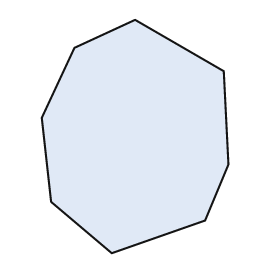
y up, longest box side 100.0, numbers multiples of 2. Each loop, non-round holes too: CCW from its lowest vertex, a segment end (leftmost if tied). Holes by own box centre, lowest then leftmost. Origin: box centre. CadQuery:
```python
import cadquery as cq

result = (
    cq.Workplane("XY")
    .moveTo(-10.0, -50.0)
    .lineTo(30.0, -36.0)
    .lineTo(40.0, -12.0)
    .lineTo(38.0, 28.0)
    .lineTo(0.0, 50.0)
    .lineTo(-26.0, 38.0)
    .lineTo(-40.0, 8.0)
    .lineTo(-36.0, -28.0)
    .close()
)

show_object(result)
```